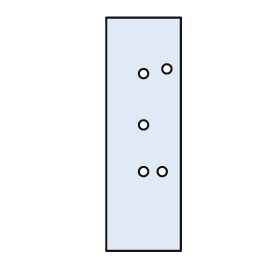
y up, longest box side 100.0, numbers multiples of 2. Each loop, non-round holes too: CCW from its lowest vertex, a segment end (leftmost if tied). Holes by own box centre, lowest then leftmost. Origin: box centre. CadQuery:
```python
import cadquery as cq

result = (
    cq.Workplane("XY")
    .moveTo(-16.0, -50.0)
    .lineTo(16.0, -50.0)
    .lineTo(16.0, 50.0)
    .lineTo(-16.0, 50.0)
    .close()
    .moveTo(0.0, -16.0)
    .circle(2.0)
    .moveTo(8.0, -16.0)
    .circle(2.0)
    .moveTo(0.0, 4.0)
    .circle(2.0)
    .moveTo(0.0, 26.0)
    .circle(2.0)
    .moveTo(10.0, 28.0)
    .circle(2.0)
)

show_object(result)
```